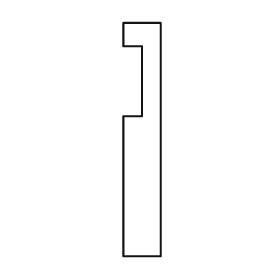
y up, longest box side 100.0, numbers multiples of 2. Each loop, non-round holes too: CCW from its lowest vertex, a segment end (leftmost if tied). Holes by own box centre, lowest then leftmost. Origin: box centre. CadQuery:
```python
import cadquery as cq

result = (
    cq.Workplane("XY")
    .moveTo(-8.0, -50.0)
    .lineTo(8.0, -50.0)
    .lineTo(8.0, 50.0)
    .lineTo(-8.0, 50.0)
    .lineTo(-8.0, 40.0)
    .lineTo(0.0, 40.0)
    .lineTo(0.0, 10.0)
    .lineTo(-8.0, 10.0)
    .close()
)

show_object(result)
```